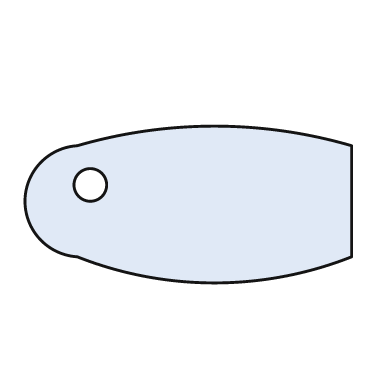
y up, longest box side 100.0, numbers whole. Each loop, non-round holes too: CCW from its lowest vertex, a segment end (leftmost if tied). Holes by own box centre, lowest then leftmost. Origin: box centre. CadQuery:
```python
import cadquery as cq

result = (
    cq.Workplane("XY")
    .moveTo(-34.0, -16.0)
    .threePointArc((8.0, -24.0), (50.0, -16.0))
    .lineTo(50.0, 18.0)
    .threePointArc((8.0, 24.0), (-34.0, 18.0))
    .threePointArc((-50.0, 1.0), (-34.0, -16.0))
    .close()
    .moveTo(-30.0, 6.0)
    .circle(5.0)
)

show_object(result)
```